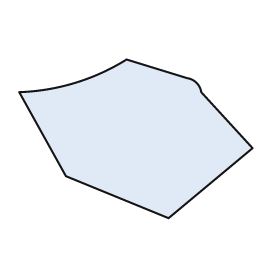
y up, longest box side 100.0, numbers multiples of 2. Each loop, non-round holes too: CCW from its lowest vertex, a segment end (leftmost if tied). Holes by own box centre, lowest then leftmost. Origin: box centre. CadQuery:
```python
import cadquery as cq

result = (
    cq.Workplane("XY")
    .moveTo(14.0, -34.0)
    .lineTo(50.0, -4.0)
    .lineTo(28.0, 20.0)
    .threePointArc((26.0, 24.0), (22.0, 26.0))
    .lineTo(-4.0, 34.0)
    .threePointArc((-26.0, 24.0), (-50.0, 20.0))
    .lineTo(-30.0, -16.0)
    .close()
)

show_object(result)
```